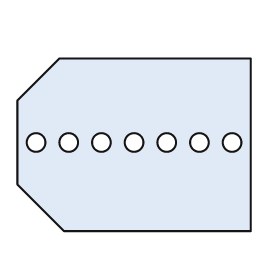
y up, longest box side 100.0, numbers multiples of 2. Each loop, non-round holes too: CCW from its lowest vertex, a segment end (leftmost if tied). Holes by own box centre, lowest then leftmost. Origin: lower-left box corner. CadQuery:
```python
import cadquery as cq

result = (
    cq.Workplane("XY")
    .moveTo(20.0, 0.0)
    .lineTo(100.0, 0.0)
    .lineTo(100.0, 74.0)
    .lineTo(18.0, 74.0)
    .lineTo(0.0, 56.0)
    .lineTo(0.0, 20.0)
    .close()
    .moveTo(8.0, 38.0)
    .circle(4.0)
    .moveTo(22.0, 38.0)
    .circle(4.0)
    .moveTo(36.0, 38.0)
    .circle(4.0)
    .moveTo(50.0, 38.0)
    .circle(4.0)
    .moveTo(64.0, 38.0)
    .circle(4.0)
    .moveTo(78.0, 38.0)
    .circle(4.0)
    .moveTo(92.0, 38.0)
    .circle(4.0)
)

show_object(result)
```